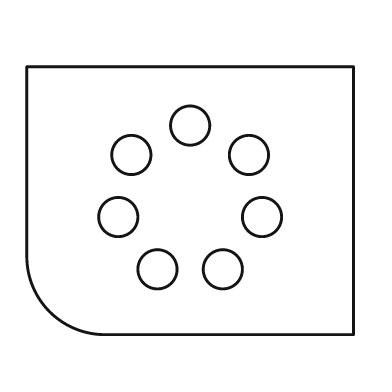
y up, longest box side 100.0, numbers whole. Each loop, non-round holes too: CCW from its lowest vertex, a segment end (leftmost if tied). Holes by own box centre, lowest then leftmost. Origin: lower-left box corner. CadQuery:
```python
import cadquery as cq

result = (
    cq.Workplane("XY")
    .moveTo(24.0, 0.0)
    .lineTo(100.0, 0.0)
    .lineTo(100.0, 82.0)
    .lineTo(0.0, 82.0)
    .lineTo(0.0, 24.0)
    .threePointArc((7.0, 7.0), (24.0, 0.0))
    .close()
    .moveTo(40.0, 20.0)
    .circle(6.0)
    .moveTo(60.0, 20.0)
    .circle(6.0)
    .moveTo(28.0, 36.0)
    .circle(6.0)
    .moveTo(72.0, 36.0)
    .circle(6.0)
    .moveTo(32.0, 55.0)
    .circle(6.0)
    .moveTo(68.0, 55.0)
    .circle(6.0)
    .moveTo(50.0, 64.0)
    .circle(6.0)
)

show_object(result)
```